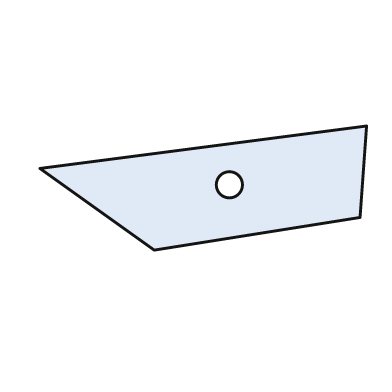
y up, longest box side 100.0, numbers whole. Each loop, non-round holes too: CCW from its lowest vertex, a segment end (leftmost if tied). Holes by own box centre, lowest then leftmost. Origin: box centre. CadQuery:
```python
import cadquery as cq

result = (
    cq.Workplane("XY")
    .moveTo(-15.0, -19.0)
    .lineTo(48.0, -9.0)
    .lineTo(50.0, 19.0)
    .lineTo(-50.0, 6.0)
    .close()
    .moveTo(8.0, 1.0)
    .circle(4.0)
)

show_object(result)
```